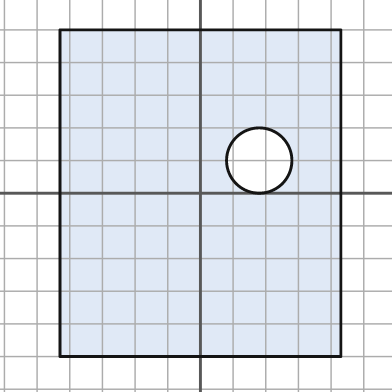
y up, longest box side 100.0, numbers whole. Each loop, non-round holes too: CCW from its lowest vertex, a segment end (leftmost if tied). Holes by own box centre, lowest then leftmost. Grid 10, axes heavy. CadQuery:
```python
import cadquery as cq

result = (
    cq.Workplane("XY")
    .moveTo(-43.0, -50.0)
    .lineTo(43.0, -50.0)
    .lineTo(43.0, 50.0)
    .lineTo(-43.0, 50.0)
    .close()
    .moveTo(18.0, 10.0)
    .circle(10.0)
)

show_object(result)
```